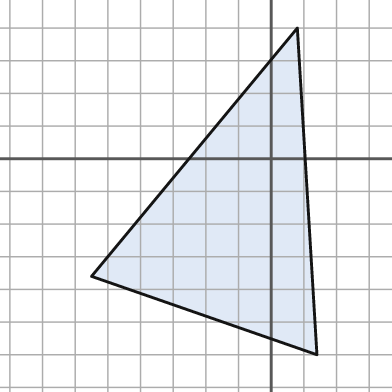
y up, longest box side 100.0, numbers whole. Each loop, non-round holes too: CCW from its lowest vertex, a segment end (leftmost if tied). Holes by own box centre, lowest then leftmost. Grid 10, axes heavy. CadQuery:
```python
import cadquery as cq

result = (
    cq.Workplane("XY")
    .moveTo(14.0, -60.0)
    .lineTo(8.0, 40.0)
    .lineTo(-55.0, -36.0)
    .close()
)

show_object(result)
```